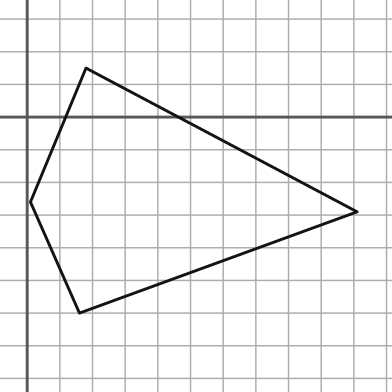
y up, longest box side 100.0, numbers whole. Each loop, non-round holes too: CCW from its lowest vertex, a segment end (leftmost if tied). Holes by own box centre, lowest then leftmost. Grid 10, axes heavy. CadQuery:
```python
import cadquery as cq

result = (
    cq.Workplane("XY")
    .moveTo(16.0, -60.0)
    .lineTo(101.0, -29.0)
    .lineTo(18.0, 15.0)
    .lineTo(1.0, -26.0)
    .close()
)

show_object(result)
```